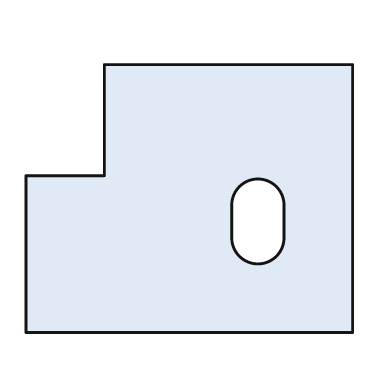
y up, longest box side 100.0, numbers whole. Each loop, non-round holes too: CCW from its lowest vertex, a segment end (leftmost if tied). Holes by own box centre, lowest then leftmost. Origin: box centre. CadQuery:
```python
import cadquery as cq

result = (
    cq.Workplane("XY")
    .moveTo(-50.0, -41.0)
    .lineTo(50.0, -41.0)
    .lineTo(50.0, 41.0)
    .lineTo(-26.0, 41.0)
    .lineTo(-26.0, 7.0)
    .lineTo(-50.0, 7.0)
    .close()
    .moveTo(13.0, -12.0)
    .threePointArc((21.0, -20.0), (29.0, -12.0))
    .lineTo(29.0, -2.0)
    .threePointArc((21.0, 6.0), (13.0, -2.0))
    .close()
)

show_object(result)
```